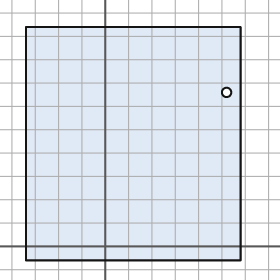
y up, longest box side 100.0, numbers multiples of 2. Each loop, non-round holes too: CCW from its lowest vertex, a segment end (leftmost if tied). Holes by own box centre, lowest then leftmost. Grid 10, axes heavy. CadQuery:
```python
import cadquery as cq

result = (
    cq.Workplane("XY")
    .moveTo(-34.0, -6.0)
    .lineTo(58.0, -6.0)
    .lineTo(58.0, 94.0)
    .lineTo(-34.0, 94.0)
    .close()
    .moveTo(52.0, 66.0)
    .circle(2.0)
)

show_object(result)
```